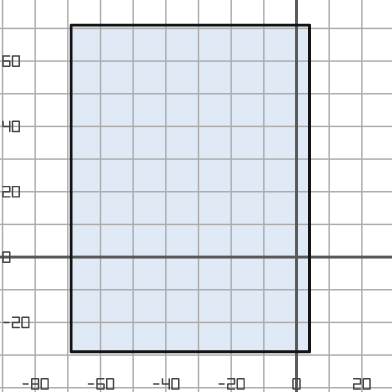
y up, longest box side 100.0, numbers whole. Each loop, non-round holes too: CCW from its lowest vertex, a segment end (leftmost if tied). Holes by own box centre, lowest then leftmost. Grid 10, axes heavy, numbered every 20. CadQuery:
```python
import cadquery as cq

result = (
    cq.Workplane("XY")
    .moveTo(-69.0, -29.0)
    .lineTo(4.0, -29.0)
    .lineTo(4.0, 71.0)
    .lineTo(-69.0, 71.0)
    .close()
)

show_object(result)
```